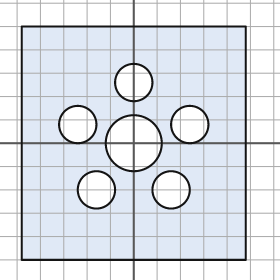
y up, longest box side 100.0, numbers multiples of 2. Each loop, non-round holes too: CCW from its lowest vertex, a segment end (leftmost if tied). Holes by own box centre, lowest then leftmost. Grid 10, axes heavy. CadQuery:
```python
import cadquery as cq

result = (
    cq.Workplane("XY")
    .moveTo(-48.0, -50.0)
    .lineTo(48.0, -50.0)
    .lineTo(48.0, 50.0)
    .lineTo(-48.0, 50.0)
    .close()
    .moveTo(-16.0, -20.0)
    .circle(8.0)
    .moveTo(16.0, -20.0)
    .circle(8.0)
    .moveTo(0.0, 0.0)
    .circle(12.0)
    .moveTo(-24.0, 8.0)
    .circle(8.0)
    .moveTo(24.0, 8.0)
    .circle(8.0)
    .moveTo(0.0, 26.0)
    .circle(8.0)
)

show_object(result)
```